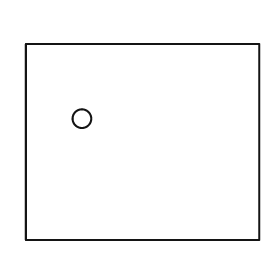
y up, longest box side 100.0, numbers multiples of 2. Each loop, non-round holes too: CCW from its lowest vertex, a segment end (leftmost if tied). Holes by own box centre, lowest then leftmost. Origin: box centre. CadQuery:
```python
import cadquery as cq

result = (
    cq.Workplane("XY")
    .moveTo(-50.0, -42.0)
    .lineTo(50.0, -42.0)
    .lineTo(50.0, 42.0)
    .lineTo(-50.0, 42.0)
    .close()
    .moveTo(-26.0, 10.0)
    .circle(4.0)
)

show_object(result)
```